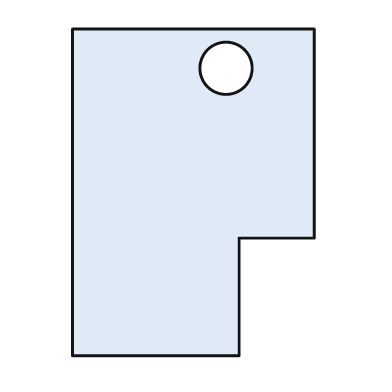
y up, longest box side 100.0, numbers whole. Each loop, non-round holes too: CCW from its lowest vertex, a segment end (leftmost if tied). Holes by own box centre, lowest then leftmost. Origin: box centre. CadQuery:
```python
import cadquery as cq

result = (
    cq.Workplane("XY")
    .moveTo(-37.0, -50.0)
    .lineTo(14.0, -50.0)
    .lineTo(14.0, -14.0)
    .lineTo(37.0, -14.0)
    .lineTo(37.0, 50.0)
    .lineTo(-37.0, 50.0)
    .close()
    .moveTo(10.0, 38.0)
    .circle(8.0)
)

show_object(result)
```